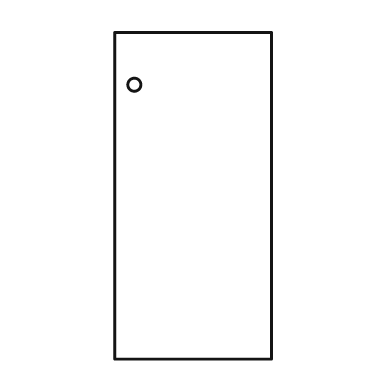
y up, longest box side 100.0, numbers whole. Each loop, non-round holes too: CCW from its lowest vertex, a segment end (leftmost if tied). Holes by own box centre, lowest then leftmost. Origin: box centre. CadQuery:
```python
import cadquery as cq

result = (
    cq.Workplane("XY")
    .moveTo(-24.0, -50.0)
    .lineTo(24.0, -50.0)
    .lineTo(24.0, 50.0)
    .lineTo(-24.0, 50.0)
    .close()
    .moveTo(-18.0, 34.0)
    .circle(2.0)
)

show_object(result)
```